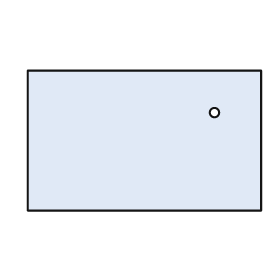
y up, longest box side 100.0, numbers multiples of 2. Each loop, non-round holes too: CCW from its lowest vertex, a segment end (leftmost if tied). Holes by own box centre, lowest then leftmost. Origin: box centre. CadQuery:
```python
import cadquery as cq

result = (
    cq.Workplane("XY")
    .moveTo(-50.0, -30.0)
    .lineTo(50.0, -30.0)
    .lineTo(50.0, 30.0)
    .lineTo(-50.0, 30.0)
    .close()
    .moveTo(30.0, 12.0)
    .circle(2.0)
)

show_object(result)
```